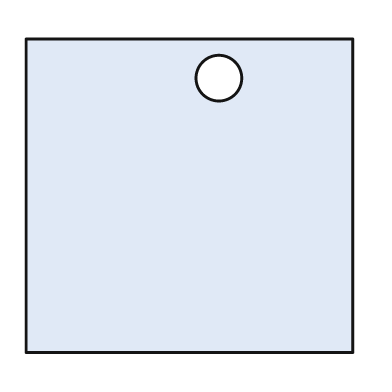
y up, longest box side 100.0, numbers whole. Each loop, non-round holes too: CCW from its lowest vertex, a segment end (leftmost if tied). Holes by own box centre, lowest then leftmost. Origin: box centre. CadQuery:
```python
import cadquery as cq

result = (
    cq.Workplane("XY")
    .moveTo(-50.0, -48.0)
    .lineTo(50.0, -48.0)
    .lineTo(50.0, 48.0)
    .lineTo(-50.0, 48.0)
    .close()
    .moveTo(9.0, 36.0)
    .circle(7.0)
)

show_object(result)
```